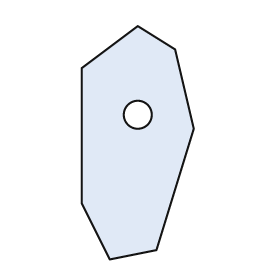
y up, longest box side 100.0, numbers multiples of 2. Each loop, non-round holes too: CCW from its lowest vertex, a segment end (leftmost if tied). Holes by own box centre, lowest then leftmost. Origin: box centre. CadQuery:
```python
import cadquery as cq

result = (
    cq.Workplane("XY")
    .moveTo(-12.0, -50.0)
    .lineTo(8.0, -46.0)
    .lineTo(24.0, 6.0)
    .lineTo(16.0, 40.0)
    .lineTo(0.0, 50.0)
    .lineTo(-24.0, 32.0)
    .lineTo(-24.0, -26.0)
    .close()
    .moveTo(0.0, 12.0)
    .circle(6.0)
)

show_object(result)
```